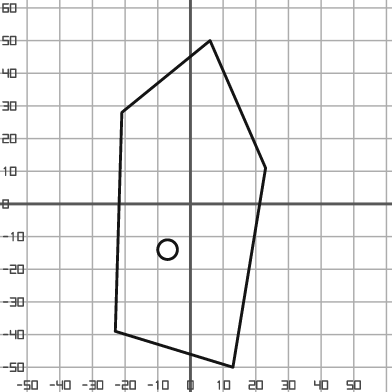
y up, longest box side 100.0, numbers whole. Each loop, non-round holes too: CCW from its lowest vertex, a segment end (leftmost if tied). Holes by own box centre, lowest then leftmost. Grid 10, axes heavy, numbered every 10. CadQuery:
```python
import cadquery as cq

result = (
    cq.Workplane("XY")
    .moveTo(13.0, -50.0)
    .lineTo(23.0, 11.0)
    .lineTo(6.0, 50.0)
    .lineTo(-21.0, 28.0)
    .lineTo(-23.0, -39.0)
    .close()
    .moveTo(-7.0, -14.0)
    .circle(3.0)
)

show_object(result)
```